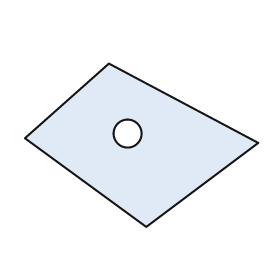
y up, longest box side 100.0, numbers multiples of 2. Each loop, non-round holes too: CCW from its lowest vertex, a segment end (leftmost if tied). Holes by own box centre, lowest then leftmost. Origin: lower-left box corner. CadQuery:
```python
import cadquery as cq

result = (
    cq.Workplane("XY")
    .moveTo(52.0, 0.0)
    .lineTo(100.0, 36.0)
    .lineTo(36.0, 70.0)
    .lineTo(0.0, 38.0)
    .close()
    .moveTo(44.0, 40.0)
    .circle(6.0)
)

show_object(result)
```